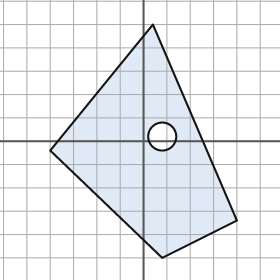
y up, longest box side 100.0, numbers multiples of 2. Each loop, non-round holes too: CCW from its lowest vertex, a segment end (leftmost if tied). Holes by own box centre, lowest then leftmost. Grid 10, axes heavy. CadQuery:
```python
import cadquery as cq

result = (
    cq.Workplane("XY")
    .moveTo(8.0, -50.0)
    .lineTo(40.0, -34.0)
    .lineTo(4.0, 50.0)
    .lineTo(-40.0, -4.0)
    .close()
    .moveTo(8.0, 2.0)
    .circle(6.0)
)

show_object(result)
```